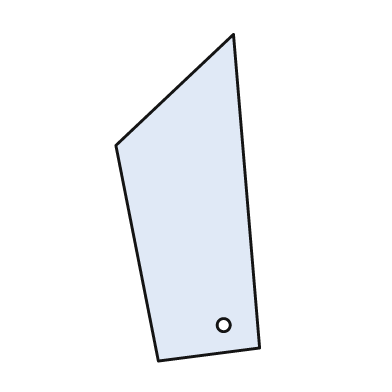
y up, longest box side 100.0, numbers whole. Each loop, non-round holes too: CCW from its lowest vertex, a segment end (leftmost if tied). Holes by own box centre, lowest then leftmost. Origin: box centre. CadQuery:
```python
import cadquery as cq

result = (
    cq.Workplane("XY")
    .moveTo(-9.0, -50.0)
    .lineTo(22.0, -46.0)
    .lineTo(14.0, 50.0)
    .lineTo(-22.0, 16.0)
    .close()
    .moveTo(11.0, -39.0)
    .circle(2.0)
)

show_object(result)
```